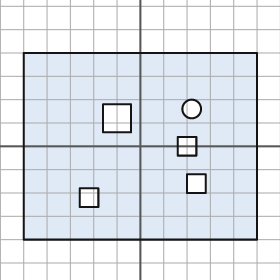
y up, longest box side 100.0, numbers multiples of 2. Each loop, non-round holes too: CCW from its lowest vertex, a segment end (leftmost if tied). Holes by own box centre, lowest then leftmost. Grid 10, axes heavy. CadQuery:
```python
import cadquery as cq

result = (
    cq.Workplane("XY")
    .moveTo(-50.0, -40.0)
    .lineTo(50.0, -40.0)
    .lineTo(50.0, 40.0)
    .lineTo(-50.0, 40.0)
    .close()
    .moveTo(-26.0, -26.0)
    .lineTo(-18.0, -26.0)
    .lineTo(-18.0, -18.0)
    .lineTo(-26.0, -18.0)
    .close()
    .moveTo(20.0, -20.0)
    .lineTo(28.0, -20.0)
    .lineTo(28.0, -12.0)
    .lineTo(20.0, -12.0)
    .close()
    .moveTo(16.0, -4.0)
    .lineTo(24.0, -4.0)
    .lineTo(24.0, 4.0)
    .lineTo(16.0, 4.0)
    .close()
    .moveTo(-16.0, 6.0)
    .lineTo(-4.0, 6.0)
    .lineTo(-4.0, 18.0)
    .lineTo(-16.0, 18.0)
    .close()
    .moveTo(22.0, 16.0)
    .circle(4.0)
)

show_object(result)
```